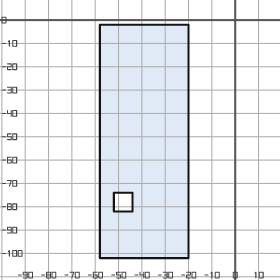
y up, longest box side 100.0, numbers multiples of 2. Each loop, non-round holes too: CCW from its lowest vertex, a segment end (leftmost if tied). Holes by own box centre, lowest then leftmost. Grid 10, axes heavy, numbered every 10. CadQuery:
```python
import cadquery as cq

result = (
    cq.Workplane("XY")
    .moveTo(-58.0, -102.0)
    .lineTo(-20.0, -102.0)
    .lineTo(-20.0, -2.0)
    .lineTo(-58.0, -2.0)
    .close()
    .moveTo(-52.0, -82.0)
    .lineTo(-44.0, -82.0)
    .lineTo(-44.0, -74.0)
    .lineTo(-52.0, -74.0)
    .close()
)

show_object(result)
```